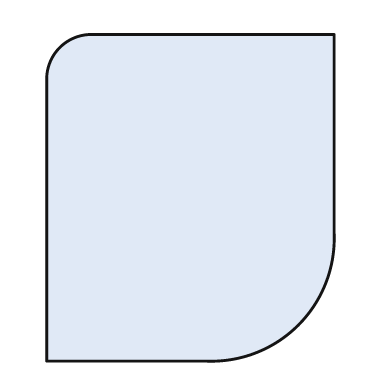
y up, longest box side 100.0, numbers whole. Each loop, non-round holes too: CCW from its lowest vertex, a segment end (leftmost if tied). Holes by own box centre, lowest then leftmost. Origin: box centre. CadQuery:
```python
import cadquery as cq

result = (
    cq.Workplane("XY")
    .moveTo(-44.0, -50.0)
    .lineTo(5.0, -50.0)
    .threePointArc((33.0, -39.0), (44.0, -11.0))
    .lineTo(44.0, 50.0)
    .lineTo(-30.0, 50.0)
    .threePointArc((-40.0, 46.0), (-44.0, 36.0))
    .close()
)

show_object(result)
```